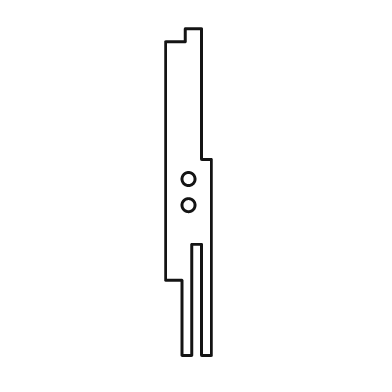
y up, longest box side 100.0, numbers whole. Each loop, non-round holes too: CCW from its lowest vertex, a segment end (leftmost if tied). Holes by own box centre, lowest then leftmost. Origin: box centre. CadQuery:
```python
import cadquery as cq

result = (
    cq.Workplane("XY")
    .moveTo(-2.0, -50.0)
    .lineTo(1.0, -50.0)
    .lineTo(1.0, -16.0)
    .lineTo(4.0, -16.0)
    .lineTo(4.0, -50.0)
    .lineTo(7.0, -50.0)
    .lineTo(7.0, 10.0)
    .lineTo(4.0, 10.0)
    .lineTo(4.0, 50.0)
    .lineTo(-1.0, 50.0)
    .lineTo(-1.0, 46.0)
    .lineTo(-7.0, 46.0)
    .lineTo(-7.0, -27.0)
    .lineTo(-2.0, -27.0)
    .close()
    .moveTo(0.0, -4.0)
    .circle(2.0)
    .moveTo(0.0, 4.0)
    .circle(2.0)
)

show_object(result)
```